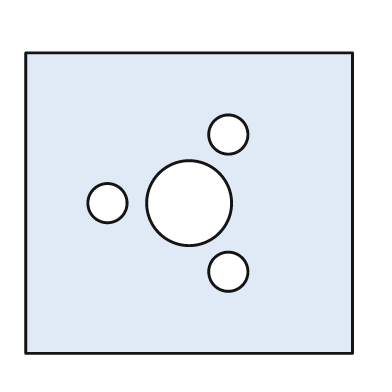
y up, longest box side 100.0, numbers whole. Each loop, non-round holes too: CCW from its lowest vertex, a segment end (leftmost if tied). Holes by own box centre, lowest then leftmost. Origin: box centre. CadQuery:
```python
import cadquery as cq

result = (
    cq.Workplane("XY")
    .moveTo(-50.0, -46.0)
    .lineTo(50.0, -46.0)
    .lineTo(50.0, 46.0)
    .lineTo(-50.0, 46.0)
    .close()
    .moveTo(12.0, -21.0)
    .circle(6.0)
    .moveTo(-25.0, 0.0)
    .circle(6.0)
    .moveTo(0.0, 0.0)
    .circle(13.0)
    .moveTo(12.0, 21.0)
    .circle(6.0)
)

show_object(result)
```